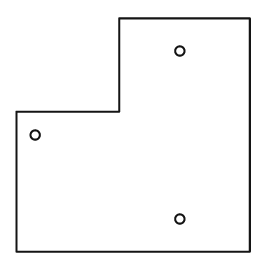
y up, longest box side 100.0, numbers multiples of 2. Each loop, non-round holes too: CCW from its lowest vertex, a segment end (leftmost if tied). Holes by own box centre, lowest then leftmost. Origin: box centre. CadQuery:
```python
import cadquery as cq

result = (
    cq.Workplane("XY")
    .moveTo(-50.0, -50.0)
    .lineTo(50.0, -50.0)
    .lineTo(50.0, 50.0)
    .lineTo(-6.0, 50.0)
    .lineTo(-6.0, 10.0)
    .lineTo(-50.0, 10.0)
    .close()
    .moveTo(20.0, -36.0)
    .circle(2.0)
    .moveTo(-42.0, 0.0)
    .circle(2.0)
    .moveTo(20.0, 36.0)
    .circle(2.0)
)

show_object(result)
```